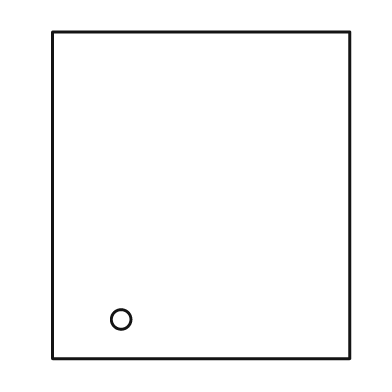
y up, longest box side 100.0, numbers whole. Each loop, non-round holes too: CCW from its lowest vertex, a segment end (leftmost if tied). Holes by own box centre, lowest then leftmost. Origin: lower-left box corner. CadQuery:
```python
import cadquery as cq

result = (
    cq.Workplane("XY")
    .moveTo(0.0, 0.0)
    .lineTo(91.0, 0.0)
    .lineTo(91.0, 100.0)
    .lineTo(0.0, 100.0)
    .close()
    .moveTo(21.0, 12.0)
    .circle(3.0)
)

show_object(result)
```